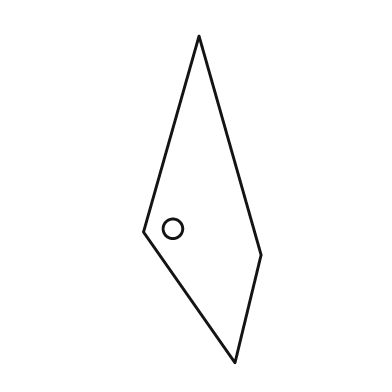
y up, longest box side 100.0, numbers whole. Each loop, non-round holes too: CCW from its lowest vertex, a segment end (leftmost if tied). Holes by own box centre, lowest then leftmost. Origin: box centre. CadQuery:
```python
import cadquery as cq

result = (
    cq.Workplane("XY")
    .moveTo(10.0, -50.0)
    .lineTo(18.0, -17.0)
    .lineTo(-1.0, 50.0)
    .lineTo(-18.0, -10.0)
    .close()
    .moveTo(-9.0, -9.0)
    .circle(3.0)
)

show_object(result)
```